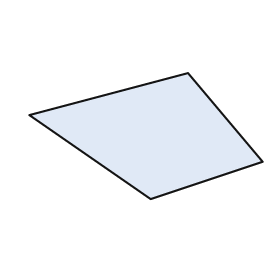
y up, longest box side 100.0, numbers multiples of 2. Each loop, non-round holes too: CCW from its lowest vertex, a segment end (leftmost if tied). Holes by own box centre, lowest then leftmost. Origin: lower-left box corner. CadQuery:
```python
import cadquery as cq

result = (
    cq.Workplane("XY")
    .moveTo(52.0, 0.0)
    .lineTo(100.0, 16.0)
    .lineTo(68.0, 54.0)
    .lineTo(0.0, 36.0)
    .close()
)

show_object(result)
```